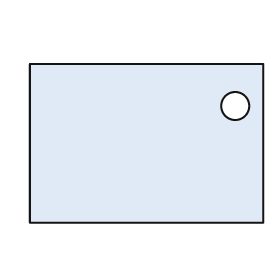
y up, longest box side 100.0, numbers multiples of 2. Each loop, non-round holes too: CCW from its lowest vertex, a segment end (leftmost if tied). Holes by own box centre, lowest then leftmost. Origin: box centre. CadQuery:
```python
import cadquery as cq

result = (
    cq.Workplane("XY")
    .moveTo(-50.0, -34.0)
    .lineTo(50.0, -34.0)
    .lineTo(50.0, 34.0)
    .lineTo(-50.0, 34.0)
    .close()
    .moveTo(38.0, 16.0)
    .circle(6.0)
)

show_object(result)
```